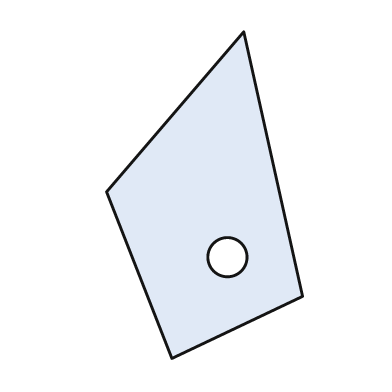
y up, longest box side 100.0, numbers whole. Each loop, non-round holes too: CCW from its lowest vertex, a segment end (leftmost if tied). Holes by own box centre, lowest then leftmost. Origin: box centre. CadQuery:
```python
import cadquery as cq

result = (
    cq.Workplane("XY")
    .moveTo(-10.0, -50.0)
    .lineTo(30.0, -31.0)
    .lineTo(12.0, 50.0)
    .lineTo(-30.0, 1.0)
    .close()
    .moveTo(7.0, -19.0)
    .circle(6.0)
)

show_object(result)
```